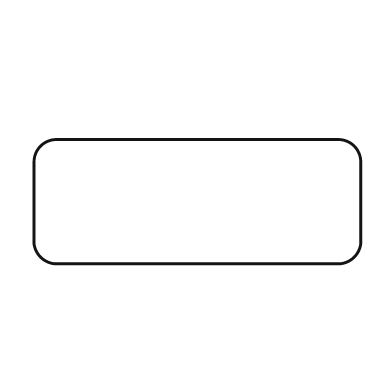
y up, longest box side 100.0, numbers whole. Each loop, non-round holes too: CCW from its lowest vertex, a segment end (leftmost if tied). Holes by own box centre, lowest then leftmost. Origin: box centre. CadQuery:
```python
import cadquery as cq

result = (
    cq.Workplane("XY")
    .moveTo(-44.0, -19.0)
    .lineTo(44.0, -19.0)
    .threePointArc((48.0, -17.0), (50.0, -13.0))
    .lineTo(50.0, 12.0)
    .threePointArc((48.0, 17.0), (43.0, 19.0))
    .lineTo(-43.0, 19.0)
    .threePointArc((-48.0, 17.0), (-50.0, 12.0))
    .lineTo(-50.0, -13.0)
    .threePointArc((-48.0, -17.0), (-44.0, -19.0))
    .close()
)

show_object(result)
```